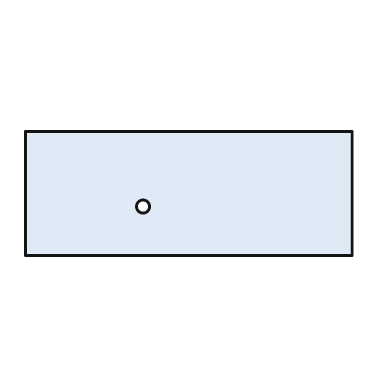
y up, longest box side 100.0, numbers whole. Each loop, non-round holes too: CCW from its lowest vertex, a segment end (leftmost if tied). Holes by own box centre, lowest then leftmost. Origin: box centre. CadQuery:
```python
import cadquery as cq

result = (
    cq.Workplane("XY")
    .moveTo(-50.0, -19.0)
    .lineTo(50.0, -19.0)
    .lineTo(50.0, 19.0)
    .lineTo(-50.0, 19.0)
    .close()
    .moveTo(-14.0, -4.0)
    .circle(2.0)
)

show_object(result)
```